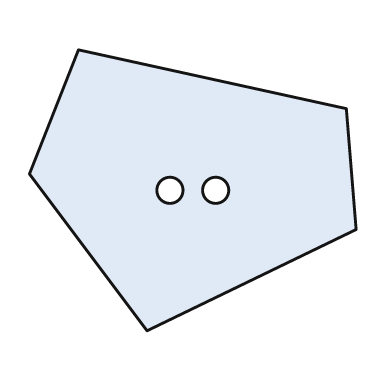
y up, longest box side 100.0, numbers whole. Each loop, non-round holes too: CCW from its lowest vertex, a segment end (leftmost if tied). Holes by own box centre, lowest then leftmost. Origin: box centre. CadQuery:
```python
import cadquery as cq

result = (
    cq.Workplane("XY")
    .moveTo(-14.0, -43.0)
    .lineTo(50.0, -12.0)
    .lineTo(47.0, 25.0)
    .lineTo(-35.0, 43.0)
    .lineTo(-50.0, 5.0)
    .close()
    .moveTo(-7.0, 0.0)
    .circle(4.0)
    .moveTo(7.0, 0.0)
    .circle(4.0)
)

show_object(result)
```